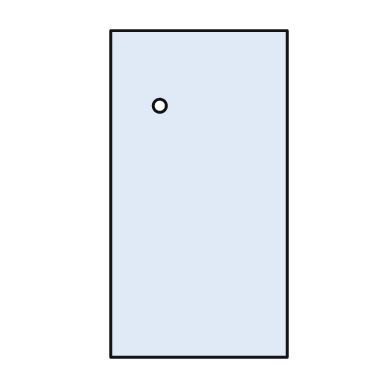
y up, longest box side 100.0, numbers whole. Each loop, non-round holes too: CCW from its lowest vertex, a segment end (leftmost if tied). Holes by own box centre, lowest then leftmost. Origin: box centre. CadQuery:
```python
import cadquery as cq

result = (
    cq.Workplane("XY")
    .moveTo(-27.0, -50.0)
    .lineTo(27.0, -50.0)
    .lineTo(27.0, 50.0)
    .lineTo(-27.0, 50.0)
    .close()
    .moveTo(-12.0, 27.0)
    .circle(2.0)
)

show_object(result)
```